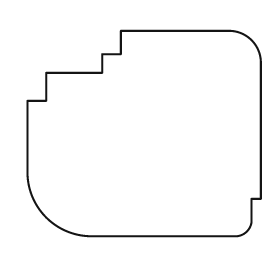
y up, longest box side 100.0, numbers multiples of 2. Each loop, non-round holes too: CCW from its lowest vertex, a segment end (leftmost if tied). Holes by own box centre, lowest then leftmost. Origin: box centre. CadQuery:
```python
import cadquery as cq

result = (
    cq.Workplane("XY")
    .moveTo(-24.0, -44.0)
    .lineTo(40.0, -44.0)
    .threePointArc((44.0, -42.0), (46.0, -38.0))
    .lineTo(46.0, -28.0)
    .lineTo(50.0, -28.0)
    .lineTo(50.0, 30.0)
    .threePointArc((46.0, 40.0), (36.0, 44.0))
    .lineTo(-10.0, 44.0)
    .lineTo(-10.0, 34.0)
    .lineTo(-18.0, 34.0)
    .lineTo(-18.0, 26.0)
    .lineTo(-42.0, 26.0)
    .lineTo(-42.0, 14.0)
    .lineTo(-50.0, 14.0)
    .lineTo(-50.0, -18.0)
    .threePointArc((-42.0, -36.0), (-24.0, -44.0))
    .close()
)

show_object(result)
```